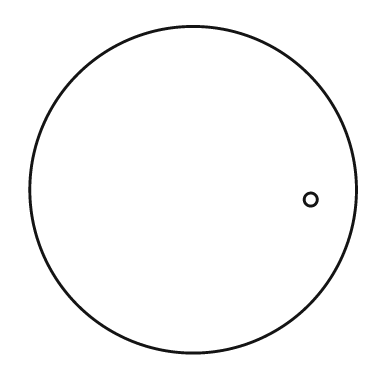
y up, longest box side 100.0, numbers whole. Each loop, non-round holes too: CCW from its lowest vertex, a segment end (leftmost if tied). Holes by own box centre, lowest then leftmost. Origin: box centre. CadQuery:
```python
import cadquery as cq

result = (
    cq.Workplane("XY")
    .moveTo(0.0, 0.0)
    .circle(50.0)
    .moveTo(36.0, -3.0)
    .circle(2.0)
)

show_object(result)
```